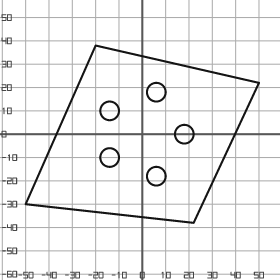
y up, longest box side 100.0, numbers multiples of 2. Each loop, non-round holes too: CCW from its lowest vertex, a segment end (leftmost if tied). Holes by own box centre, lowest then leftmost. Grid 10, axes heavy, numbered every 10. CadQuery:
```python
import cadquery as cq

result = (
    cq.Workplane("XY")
    .moveTo(22.0, -38.0)
    .lineTo(50.0, 22.0)
    .lineTo(-20.0, 38.0)
    .lineTo(-50.0, -30.0)
    .close()
    .moveTo(6.0, -18.0)
    .circle(4.0)
    .moveTo(-14.0, -10.0)
    .circle(4.0)
    .moveTo(18.0, 0.0)
    .circle(4.0)
    .moveTo(-14.0, 10.0)
    .circle(4.0)
    .moveTo(6.0, 18.0)
    .circle(4.0)
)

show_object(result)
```